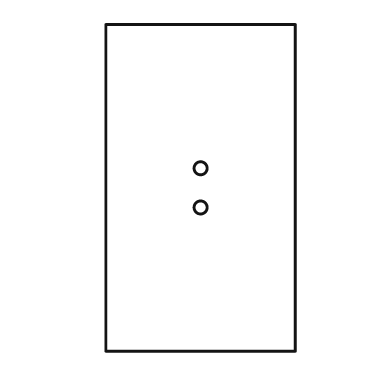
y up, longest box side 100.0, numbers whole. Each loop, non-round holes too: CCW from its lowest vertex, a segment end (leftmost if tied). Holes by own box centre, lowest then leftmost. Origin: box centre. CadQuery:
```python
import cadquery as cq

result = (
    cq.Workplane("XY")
    .moveTo(-29.0, -50.0)
    .lineTo(29.0, -50.0)
    .lineTo(29.0, 50.0)
    .lineTo(-29.0, 50.0)
    .close()
    .moveTo(0.0, -6.0)
    .circle(2.0)
    .moveTo(0.0, 6.0)
    .circle(2.0)
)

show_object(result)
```